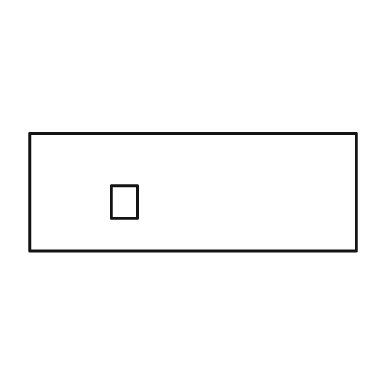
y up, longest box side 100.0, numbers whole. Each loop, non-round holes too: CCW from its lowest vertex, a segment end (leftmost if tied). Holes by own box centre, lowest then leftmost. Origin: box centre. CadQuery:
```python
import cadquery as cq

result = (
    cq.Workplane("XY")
    .moveTo(-50.0, -18.0)
    .lineTo(50.0, -18.0)
    .lineTo(50.0, 18.0)
    .lineTo(-50.0, 18.0)
    .close()
    .moveTo(-25.0, -8.0)
    .lineTo(-17.0, -8.0)
    .lineTo(-17.0, 2.0)
    .lineTo(-25.0, 2.0)
    .close()
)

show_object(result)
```